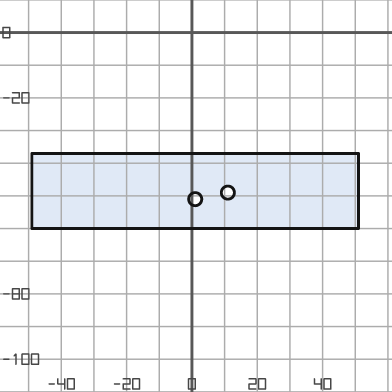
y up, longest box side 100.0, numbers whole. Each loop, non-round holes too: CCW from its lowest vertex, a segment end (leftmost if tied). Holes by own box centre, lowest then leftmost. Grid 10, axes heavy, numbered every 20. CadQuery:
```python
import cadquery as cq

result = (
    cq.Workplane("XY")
    .moveTo(-49.0, -60.0)
    .lineTo(51.0, -60.0)
    .lineTo(51.0, -37.0)
    .lineTo(-49.0, -37.0)
    .close()
    .moveTo(1.0, -51.0)
    .circle(2.0)
    .moveTo(11.0, -49.0)
    .circle(2.0)
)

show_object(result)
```